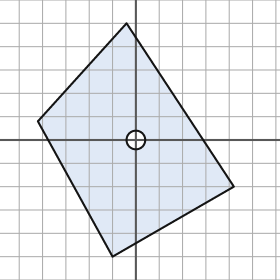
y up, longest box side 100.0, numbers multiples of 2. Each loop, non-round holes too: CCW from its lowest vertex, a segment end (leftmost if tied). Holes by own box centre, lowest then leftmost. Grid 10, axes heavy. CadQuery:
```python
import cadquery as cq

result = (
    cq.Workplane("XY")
    .moveTo(-10.0, -50.0)
    .lineTo(42.0, -20.0)
    .lineTo(-4.0, 50.0)
    .lineTo(-42.0, 8.0)
    .close()
    .moveTo(0.0, 0.0)
    .circle(4.0)
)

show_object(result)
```